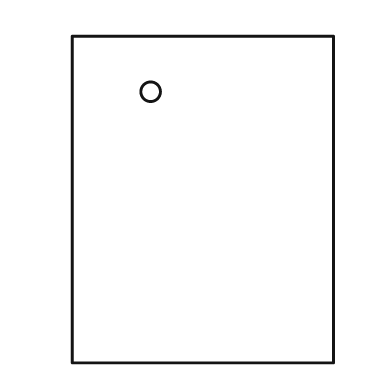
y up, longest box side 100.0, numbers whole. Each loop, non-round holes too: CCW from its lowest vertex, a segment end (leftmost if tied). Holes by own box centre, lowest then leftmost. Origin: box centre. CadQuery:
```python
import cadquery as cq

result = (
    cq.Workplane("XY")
    .moveTo(-40.0, -50.0)
    .lineTo(40.0, -50.0)
    .lineTo(40.0, 50.0)
    .lineTo(-40.0, 50.0)
    .close()
    .moveTo(-16.0, 33.0)
    .circle(3.0)
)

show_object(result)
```